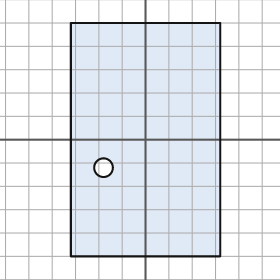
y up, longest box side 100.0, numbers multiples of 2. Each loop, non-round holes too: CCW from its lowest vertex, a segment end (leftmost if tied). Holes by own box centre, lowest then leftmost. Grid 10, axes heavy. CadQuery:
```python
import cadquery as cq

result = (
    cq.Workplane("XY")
    .moveTo(-32.0, -50.0)
    .lineTo(32.0, -50.0)
    .lineTo(32.0, 50.0)
    .lineTo(-32.0, 50.0)
    .close()
    .moveTo(-18.0, -12.0)
    .circle(4.0)
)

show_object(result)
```